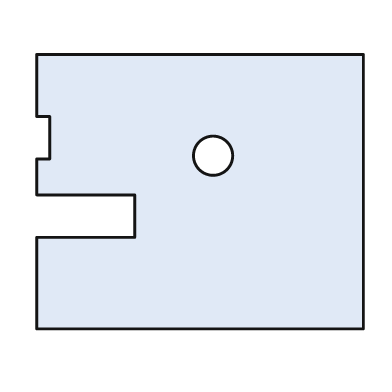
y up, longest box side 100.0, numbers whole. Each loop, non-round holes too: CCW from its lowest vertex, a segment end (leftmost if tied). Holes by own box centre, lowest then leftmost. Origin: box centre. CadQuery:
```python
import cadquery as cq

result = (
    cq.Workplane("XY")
    .moveTo(-50.0, -42.0)
    .lineTo(50.0, -42.0)
    .lineTo(50.0, 42.0)
    .lineTo(-50.0, 42.0)
    .lineTo(-50.0, 23.0)
    .lineTo(-46.0, 23.0)
    .lineTo(-46.0, 10.0)
    .lineTo(-50.0, 10.0)
    .lineTo(-50.0, -1.0)
    .lineTo(-20.0, -1.0)
    .lineTo(-20.0, -14.0)
    .lineTo(-50.0, -14.0)
    .close()
    .moveTo(4.0, 11.0)
    .circle(6.0)
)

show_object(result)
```